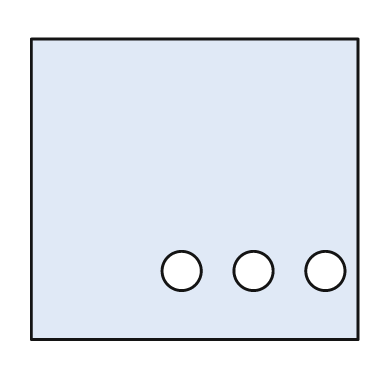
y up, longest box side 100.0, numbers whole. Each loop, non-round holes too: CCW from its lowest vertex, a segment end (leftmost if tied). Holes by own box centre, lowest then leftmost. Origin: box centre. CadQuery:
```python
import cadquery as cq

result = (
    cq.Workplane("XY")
    .moveTo(-50.0, -46.0)
    .lineTo(50.0, -46.0)
    .lineTo(50.0, 46.0)
    .lineTo(-50.0, 46.0)
    .close()
    .moveTo(-4.0, -25.0)
    .circle(6.0)
    .moveTo(18.0, -25.0)
    .circle(6.0)
    .moveTo(40.0, -25.0)
    .circle(6.0)
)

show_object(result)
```